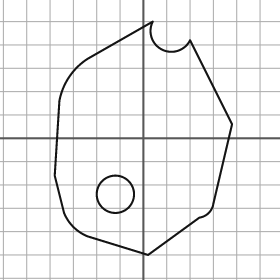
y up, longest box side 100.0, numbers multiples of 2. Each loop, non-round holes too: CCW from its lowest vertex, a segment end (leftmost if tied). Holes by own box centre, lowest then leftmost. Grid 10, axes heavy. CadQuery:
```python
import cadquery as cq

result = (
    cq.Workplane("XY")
    .moveTo(2.0, -50.0)
    .lineTo(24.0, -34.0)
    .threePointArc((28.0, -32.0), (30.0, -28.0))
    .lineTo(38.0, 6.0)
    .lineTo(20.0, 42.0)
    .threePointArc((8.0, 38.0), (4.0, 50.0))
    .lineTo(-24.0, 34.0)
    .threePointArc((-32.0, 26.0), (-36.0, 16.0))
    .lineTo(-38.0, -16.0)
    .lineTo(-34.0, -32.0)
    .threePointArc((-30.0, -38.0), (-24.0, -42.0))
    .close()
    .moveTo(-12.0, -24.0)
    .circle(8.0)
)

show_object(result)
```